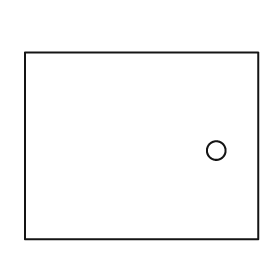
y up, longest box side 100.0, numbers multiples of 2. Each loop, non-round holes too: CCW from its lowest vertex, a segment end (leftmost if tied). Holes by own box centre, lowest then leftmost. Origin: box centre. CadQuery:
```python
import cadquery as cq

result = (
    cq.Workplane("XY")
    .moveTo(-50.0, -40.0)
    .lineTo(50.0, -40.0)
    .lineTo(50.0, 40.0)
    .lineTo(-50.0, 40.0)
    .close()
    .moveTo(32.0, -2.0)
    .circle(4.0)
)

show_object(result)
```